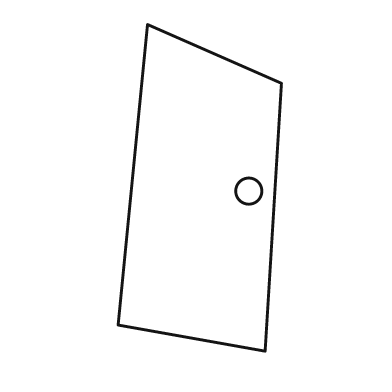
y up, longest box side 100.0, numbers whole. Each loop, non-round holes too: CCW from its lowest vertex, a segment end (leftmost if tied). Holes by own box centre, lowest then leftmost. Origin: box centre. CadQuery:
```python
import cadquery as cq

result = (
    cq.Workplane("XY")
    .moveTo(20.0, -50.0)
    .lineTo(25.0, 32.0)
    .lineTo(-16.0, 50.0)
    .lineTo(-25.0, -42.0)
    .close()
    .moveTo(15.0, -1.0)
    .circle(4.0)
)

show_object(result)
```